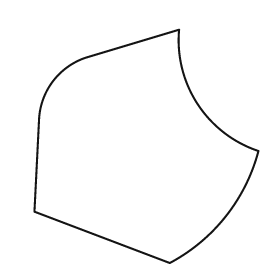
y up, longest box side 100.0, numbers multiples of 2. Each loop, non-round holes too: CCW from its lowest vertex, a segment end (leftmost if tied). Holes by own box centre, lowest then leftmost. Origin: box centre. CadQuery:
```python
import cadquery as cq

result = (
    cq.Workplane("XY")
    .moveTo(10.0, -50.0)
    .threePointArc((34.0, -30.0), (48.0, -2.0))
    .threePointArc((22.0, 18.0), (14.0, 50.0))
    .lineTo(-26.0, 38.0)
    .threePointArc((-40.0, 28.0), (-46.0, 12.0))
    .lineTo(-48.0, -28.0)
    .close()
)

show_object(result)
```